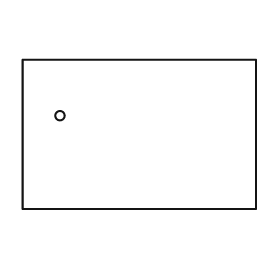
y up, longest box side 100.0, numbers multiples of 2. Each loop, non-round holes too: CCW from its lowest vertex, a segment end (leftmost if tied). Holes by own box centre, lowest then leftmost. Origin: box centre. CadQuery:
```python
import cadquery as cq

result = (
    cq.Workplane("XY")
    .moveTo(-50.0, -32.0)
    .lineTo(50.0, -32.0)
    .lineTo(50.0, 32.0)
    .lineTo(-50.0, 32.0)
    .close()
    .moveTo(-34.0, 8.0)
    .circle(2.0)
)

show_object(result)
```